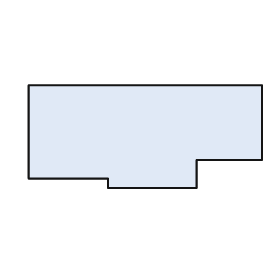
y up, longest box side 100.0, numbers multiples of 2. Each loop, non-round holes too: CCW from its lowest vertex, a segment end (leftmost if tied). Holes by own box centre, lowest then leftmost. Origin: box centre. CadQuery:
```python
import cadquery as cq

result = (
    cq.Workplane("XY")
    .moveTo(-16.0, -22.0)
    .lineTo(22.0, -22.0)
    .lineTo(22.0, -10.0)
    .lineTo(50.0, -10.0)
    .lineTo(50.0, 22.0)
    .lineTo(-50.0, 22.0)
    .lineTo(-50.0, -18.0)
    .lineTo(-16.0, -18.0)
    .close()
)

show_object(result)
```